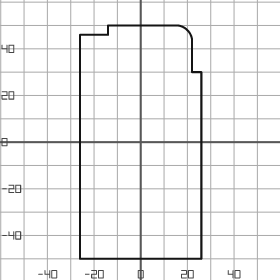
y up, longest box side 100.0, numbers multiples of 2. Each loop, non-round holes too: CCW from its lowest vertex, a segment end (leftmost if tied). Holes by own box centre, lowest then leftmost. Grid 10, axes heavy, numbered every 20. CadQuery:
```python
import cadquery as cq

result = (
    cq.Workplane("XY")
    .moveTo(-26.0, -50.0)
    .lineTo(26.0, -50.0)
    .lineTo(26.0, 30.0)
    .lineTo(22.0, 30.0)
    .lineTo(22.0, 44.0)
    .threePointArc((20.0, 48.0), (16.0, 50.0))
    .lineTo(-14.0, 50.0)
    .lineTo(-14.0, 46.0)
    .lineTo(-26.0, 46.0)
    .close()
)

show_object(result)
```